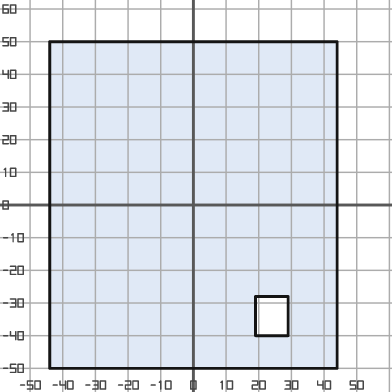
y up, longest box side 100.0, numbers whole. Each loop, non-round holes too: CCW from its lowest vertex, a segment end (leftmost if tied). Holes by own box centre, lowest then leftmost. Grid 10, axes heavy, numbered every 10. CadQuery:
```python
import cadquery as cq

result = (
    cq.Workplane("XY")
    .moveTo(-44.0, -50.0)
    .lineTo(44.0, -50.0)
    .lineTo(44.0, 50.0)
    .lineTo(-44.0, 50.0)
    .close()
    .moveTo(19.0, -40.0)
    .lineTo(29.0, -40.0)
    .lineTo(29.0, -28.0)
    .lineTo(19.0, -28.0)
    .close()
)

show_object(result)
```